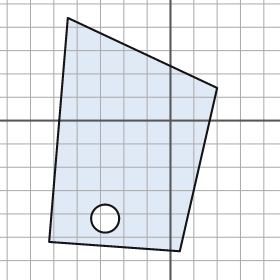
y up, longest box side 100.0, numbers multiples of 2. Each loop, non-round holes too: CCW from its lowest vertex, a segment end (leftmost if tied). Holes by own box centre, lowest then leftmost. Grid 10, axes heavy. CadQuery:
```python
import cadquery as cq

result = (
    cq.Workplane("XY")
    .moveTo(4.0, -56.0)
    .lineTo(20.0, 14.0)
    .lineTo(-44.0, 44.0)
    .lineTo(-52.0, -52.0)
    .close()
    .moveTo(-28.0, -42.0)
    .circle(6.0)
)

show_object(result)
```